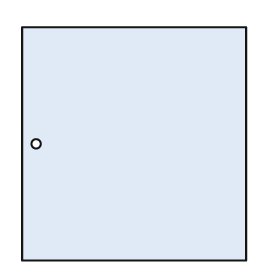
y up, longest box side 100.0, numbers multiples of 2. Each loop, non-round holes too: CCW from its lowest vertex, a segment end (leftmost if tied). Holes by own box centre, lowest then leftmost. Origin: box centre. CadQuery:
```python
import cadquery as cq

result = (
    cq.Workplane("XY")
    .moveTo(-48.0, -50.0)
    .lineTo(48.0, -50.0)
    .lineTo(48.0, 50.0)
    .lineTo(-48.0, 50.0)
    .close()
    .moveTo(-42.0, 0.0)
    .circle(2.0)
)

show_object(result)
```